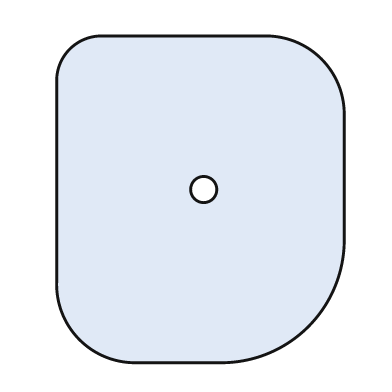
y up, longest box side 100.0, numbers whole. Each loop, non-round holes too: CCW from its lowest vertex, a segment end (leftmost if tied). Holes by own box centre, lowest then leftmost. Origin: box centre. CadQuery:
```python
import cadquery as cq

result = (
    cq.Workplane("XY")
    .moveTo(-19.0, -50.0)
    .lineTo(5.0, -50.0)
    .threePointArc((33.0, -39.0), (44.0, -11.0))
    .lineTo(44.0, 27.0)
    .threePointArc((37.0, 43.0), (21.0, 50.0))
    .lineTo(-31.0, 50.0)
    .threePointArc((-40.0, 46.0), (-44.0, 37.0))
    .lineTo(-44.0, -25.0)
    .threePointArc((-37.0, -43.0), (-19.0, -50.0))
    .close()
    .moveTo(1.0, 3.0)
    .circle(4.0)
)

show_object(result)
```